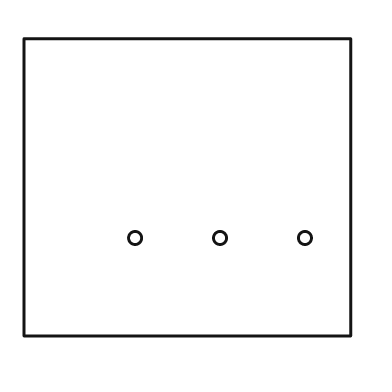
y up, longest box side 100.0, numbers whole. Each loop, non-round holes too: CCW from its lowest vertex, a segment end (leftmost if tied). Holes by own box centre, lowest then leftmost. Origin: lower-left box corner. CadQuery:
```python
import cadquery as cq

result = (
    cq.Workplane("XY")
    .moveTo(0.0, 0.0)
    .lineTo(100.0, 0.0)
    .lineTo(100.0, 91.0)
    .lineTo(0.0, 91.0)
    .close()
    .moveTo(34.0, 30.0)
    .circle(2.0)
    .moveTo(60.0, 30.0)
    .circle(2.0)
    .moveTo(86.0, 30.0)
    .circle(2.0)
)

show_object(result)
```